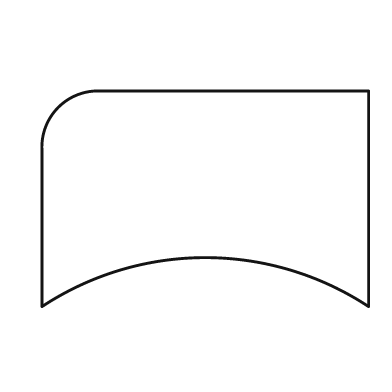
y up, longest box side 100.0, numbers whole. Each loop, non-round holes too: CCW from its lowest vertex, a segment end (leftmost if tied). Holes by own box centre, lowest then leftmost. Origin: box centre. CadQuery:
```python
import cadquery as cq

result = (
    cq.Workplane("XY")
    .moveTo(-50.0, -33.0)
    .threePointArc((0.0, -18.0), (50.0, -33.0))
    .lineTo(50.0, 33.0)
    .lineTo(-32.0, 33.0)
    .threePointArc((-45.0, 28.0), (-50.0, 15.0))
    .close()
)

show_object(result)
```